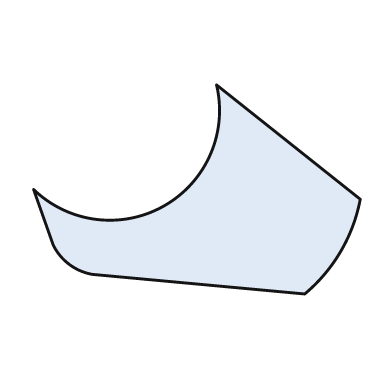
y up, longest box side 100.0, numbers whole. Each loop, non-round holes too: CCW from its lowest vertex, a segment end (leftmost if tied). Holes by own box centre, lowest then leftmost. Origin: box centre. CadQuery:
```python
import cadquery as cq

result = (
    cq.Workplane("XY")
    .moveTo(33.0, -32.0)
    .threePointArc((44.0, -19.0), (50.0, -3.0))
    .lineTo(6.0, 32.0)
    .threePointArc((-10.0, -5.0), (-50.0, 0.0))
    .lineTo(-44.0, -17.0)
    .threePointArc((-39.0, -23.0), (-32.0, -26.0))
    .close()
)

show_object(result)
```